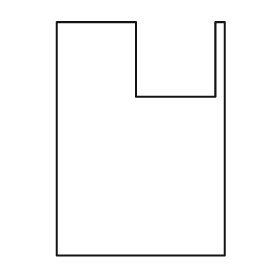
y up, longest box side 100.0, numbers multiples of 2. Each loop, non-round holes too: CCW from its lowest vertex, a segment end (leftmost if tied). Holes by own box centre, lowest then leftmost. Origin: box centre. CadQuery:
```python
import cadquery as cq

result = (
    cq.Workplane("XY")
    .moveTo(-36.0, -50.0)
    .lineTo(36.0, -50.0)
    .lineTo(36.0, 50.0)
    .lineTo(32.0, 50.0)
    .lineTo(32.0, 18.0)
    .lineTo(-2.0, 18.0)
    .lineTo(-2.0, 50.0)
    .lineTo(-36.0, 50.0)
    .close()
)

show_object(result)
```